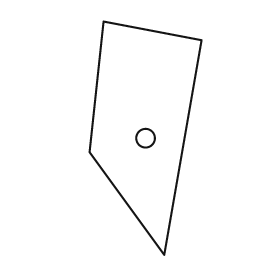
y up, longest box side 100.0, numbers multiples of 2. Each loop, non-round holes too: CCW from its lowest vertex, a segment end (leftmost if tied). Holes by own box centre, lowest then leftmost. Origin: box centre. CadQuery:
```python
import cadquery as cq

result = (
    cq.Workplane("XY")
    .moveTo(8.0, -50.0)
    .lineTo(24.0, 42.0)
    .lineTo(-18.0, 50.0)
    .lineTo(-24.0, -6.0)
    .close()
    .moveTo(0.0, 0.0)
    .circle(4.0)
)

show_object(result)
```